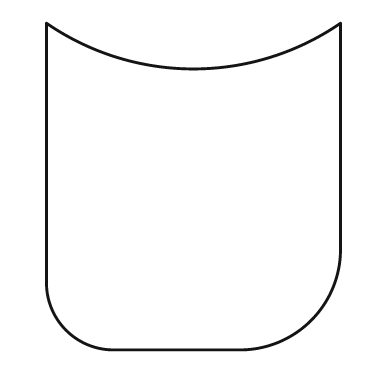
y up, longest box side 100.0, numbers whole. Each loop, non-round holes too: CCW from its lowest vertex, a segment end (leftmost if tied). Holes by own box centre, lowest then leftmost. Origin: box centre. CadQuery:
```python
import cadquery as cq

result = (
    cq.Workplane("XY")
    .moveTo(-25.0, -50.0)
    .lineTo(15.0, -50.0)
    .threePointArc((36.0, -41.0), (45.0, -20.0))
    .lineTo(45.0, 50.0)
    .threePointArc((0.0, 36.0), (-45.0, 50.0))
    .lineTo(-45.0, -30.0)
    .threePointArc((-39.0, -44.0), (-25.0, -50.0))
    .close()
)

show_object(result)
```